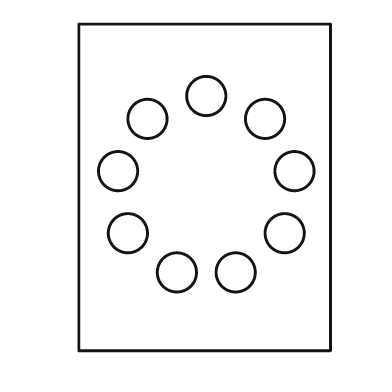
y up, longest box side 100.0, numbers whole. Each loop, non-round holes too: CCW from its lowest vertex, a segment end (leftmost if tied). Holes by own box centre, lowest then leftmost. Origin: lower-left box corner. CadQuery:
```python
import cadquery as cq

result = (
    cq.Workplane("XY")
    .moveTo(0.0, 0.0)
    .lineTo(77.0, 0.0)
    .lineTo(77.0, 100.0)
    .lineTo(0.0, 100.0)
    .close()
    .moveTo(30.0, 24.0)
    .circle(6.0)
    .moveTo(48.0, 24.0)
    .circle(6.0)
    .moveTo(15.0, 36.0)
    .circle(6.0)
    .moveTo(63.0, 36.0)
    .circle(6.0)
    .moveTo(12.0, 55.0)
    .circle(6.0)
    .moveTo(66.0, 55.0)
    .circle(6.0)
    .moveTo(21.0, 71.0)
    .circle(6.0)
    .moveTo(57.0, 71.0)
    .circle(6.0)
    .moveTo(39.0, 78.0)
    .circle(6.0)
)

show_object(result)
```